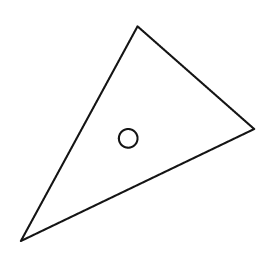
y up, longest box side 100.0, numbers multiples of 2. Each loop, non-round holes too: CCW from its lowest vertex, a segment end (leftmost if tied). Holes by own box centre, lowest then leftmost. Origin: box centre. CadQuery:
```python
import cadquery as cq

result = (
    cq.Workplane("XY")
    .moveTo(-50.0, -46.0)
    .lineTo(50.0, 2.0)
    .lineTo(0.0, 46.0)
    .close()
    .moveTo(-4.0, -2.0)
    .circle(4.0)
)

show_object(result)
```